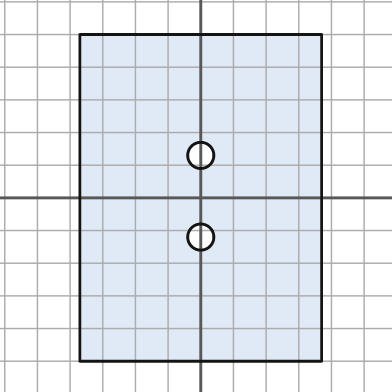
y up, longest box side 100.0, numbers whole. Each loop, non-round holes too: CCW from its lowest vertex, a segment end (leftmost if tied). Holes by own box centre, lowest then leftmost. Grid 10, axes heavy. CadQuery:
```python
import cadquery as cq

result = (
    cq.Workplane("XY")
    .moveTo(-37.0, -50.0)
    .lineTo(37.0, -50.0)
    .lineTo(37.0, 50.0)
    .lineTo(-37.0, 50.0)
    .close()
    .moveTo(0.0, -12.0)
    .circle(4.0)
    .moveTo(0.0, 13.0)
    .circle(4.0)
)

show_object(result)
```